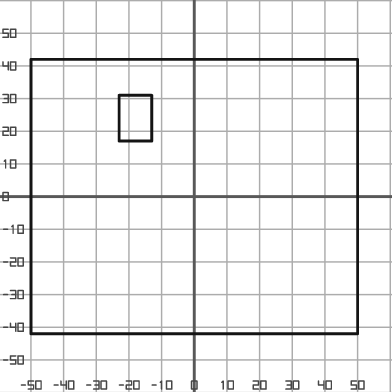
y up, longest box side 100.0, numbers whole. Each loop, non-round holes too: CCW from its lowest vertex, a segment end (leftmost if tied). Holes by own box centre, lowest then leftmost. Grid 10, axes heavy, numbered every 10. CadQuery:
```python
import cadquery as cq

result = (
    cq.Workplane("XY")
    .moveTo(-50.0, -42.0)
    .lineTo(50.0, -42.0)
    .lineTo(50.0, 42.0)
    .lineTo(-50.0, 42.0)
    .close()
    .moveTo(-23.0, 17.0)
    .lineTo(-13.0, 17.0)
    .lineTo(-13.0, 31.0)
    .lineTo(-23.0, 31.0)
    .close()
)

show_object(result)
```